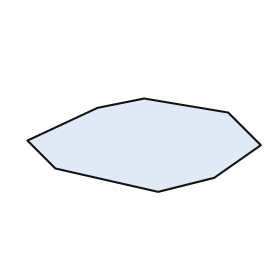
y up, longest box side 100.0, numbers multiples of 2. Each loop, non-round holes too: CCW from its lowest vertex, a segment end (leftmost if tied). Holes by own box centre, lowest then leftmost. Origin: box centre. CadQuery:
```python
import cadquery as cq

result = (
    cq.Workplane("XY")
    .moveTo(6.0, -20.0)
    .lineTo(30.0, -14.0)
    .lineTo(50.0, 0.0)
    .lineTo(36.0, 14.0)
    .lineTo(0.0, 20.0)
    .lineTo(-20.0, 16.0)
    .lineTo(-50.0, 2.0)
    .lineTo(-38.0, -10.0)
    .close()
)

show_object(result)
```